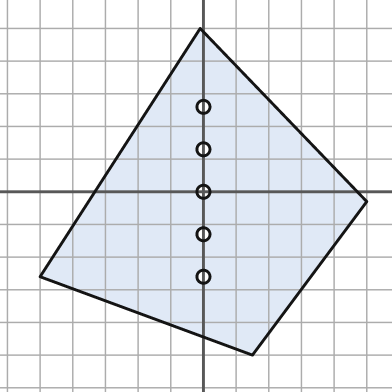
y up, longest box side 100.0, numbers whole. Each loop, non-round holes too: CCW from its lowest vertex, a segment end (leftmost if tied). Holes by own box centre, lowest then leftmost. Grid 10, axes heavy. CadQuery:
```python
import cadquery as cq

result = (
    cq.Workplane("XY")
    .moveTo(15.0, -50.0)
    .lineTo(50.0, -3.0)
    .lineTo(-1.0, 50.0)
    .lineTo(-50.0, -26.0)
    .close()
    .moveTo(0.0, -26.0)
    .circle(2.0)
    .moveTo(0.0, -13.0)
    .circle(2.0)
    .moveTo(0.0, 0.0)
    .circle(2.0)
    .moveTo(0.0, 13.0)
    .circle(2.0)
    .moveTo(0.0, 26.0)
    .circle(2.0)
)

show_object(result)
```